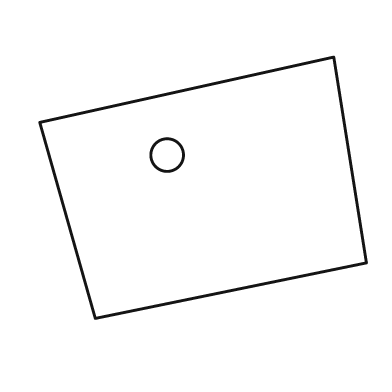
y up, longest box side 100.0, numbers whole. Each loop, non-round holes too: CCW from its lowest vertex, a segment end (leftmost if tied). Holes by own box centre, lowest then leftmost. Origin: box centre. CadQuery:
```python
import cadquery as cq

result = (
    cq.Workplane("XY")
    .moveTo(-33.0, -40.0)
    .lineTo(50.0, -23.0)
    .lineTo(40.0, 40.0)
    .lineTo(-50.0, 20.0)
    .close()
    .moveTo(-11.0, 10.0)
    .circle(5.0)
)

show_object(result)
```